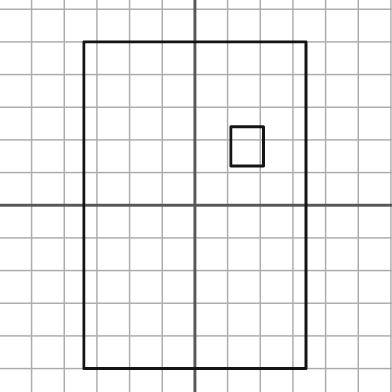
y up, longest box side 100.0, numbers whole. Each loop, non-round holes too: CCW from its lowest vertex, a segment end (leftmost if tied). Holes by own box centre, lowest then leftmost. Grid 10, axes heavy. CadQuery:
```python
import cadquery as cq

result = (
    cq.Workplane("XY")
    .moveTo(-34.0, -50.0)
    .lineTo(34.0, -50.0)
    .lineTo(34.0, 50.0)
    .lineTo(-34.0, 50.0)
    .close()
    .moveTo(11.0, 12.0)
    .lineTo(21.0, 12.0)
    .lineTo(21.0, 24.0)
    .lineTo(11.0, 24.0)
    .close()
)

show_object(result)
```